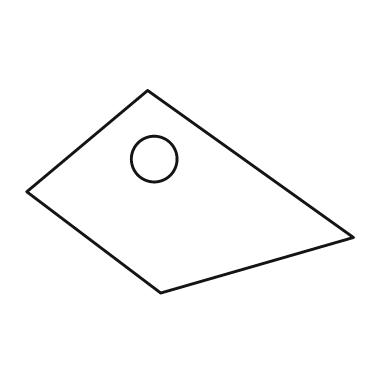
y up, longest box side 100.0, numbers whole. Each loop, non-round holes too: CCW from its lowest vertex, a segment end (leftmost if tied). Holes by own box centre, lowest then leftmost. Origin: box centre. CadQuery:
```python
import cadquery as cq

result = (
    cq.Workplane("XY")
    .moveTo(-9.0, -31.0)
    .lineTo(50.0, -14.0)
    .lineTo(-13.0, 31.0)
    .lineTo(-50.0, 0.0)
    .close()
    .moveTo(-11.0, 10.0)
    .circle(7.0)
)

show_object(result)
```